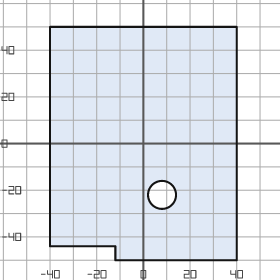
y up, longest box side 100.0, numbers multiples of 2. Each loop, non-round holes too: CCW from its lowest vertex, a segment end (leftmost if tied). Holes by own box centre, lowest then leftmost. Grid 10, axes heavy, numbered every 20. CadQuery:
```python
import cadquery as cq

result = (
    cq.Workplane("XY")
    .moveTo(-12.0, -50.0)
    .lineTo(40.0, -50.0)
    .lineTo(40.0, 50.0)
    .lineTo(-40.0, 50.0)
    .lineTo(-40.0, -44.0)
    .lineTo(-12.0, -44.0)
    .close()
    .moveTo(8.0, -22.0)
    .circle(6.0)
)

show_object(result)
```